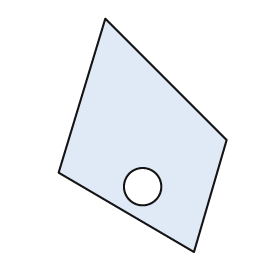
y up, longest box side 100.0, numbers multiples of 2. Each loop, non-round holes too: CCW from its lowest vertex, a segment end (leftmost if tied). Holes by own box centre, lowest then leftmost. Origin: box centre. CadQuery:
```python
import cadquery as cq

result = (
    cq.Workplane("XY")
    .moveTo(22.0, -50.0)
    .lineTo(36.0, -2.0)
    .lineTo(-16.0, 50.0)
    .lineTo(-36.0, -16.0)
    .close()
    .moveTo(0.0, -22.0)
    .circle(8.0)
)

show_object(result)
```